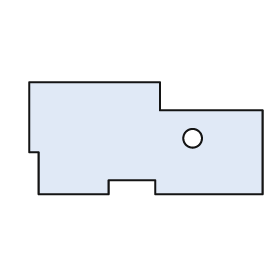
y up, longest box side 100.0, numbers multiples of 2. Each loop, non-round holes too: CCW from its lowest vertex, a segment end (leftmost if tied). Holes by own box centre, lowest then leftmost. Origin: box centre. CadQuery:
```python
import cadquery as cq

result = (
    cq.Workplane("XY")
    .moveTo(-46.0, -24.0)
    .lineTo(-16.0, -24.0)
    .lineTo(-16.0, -18.0)
    .lineTo(4.0, -18.0)
    .lineTo(4.0, -24.0)
    .lineTo(50.0, -24.0)
    .lineTo(50.0, 12.0)
    .lineTo(6.0, 12.0)
    .lineTo(6.0, 24.0)
    .lineTo(-50.0, 24.0)
    .lineTo(-50.0, -6.0)
    .lineTo(-46.0, -6.0)
    .close()
    .moveTo(20.0, 0.0)
    .circle(4.0)
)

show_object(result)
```